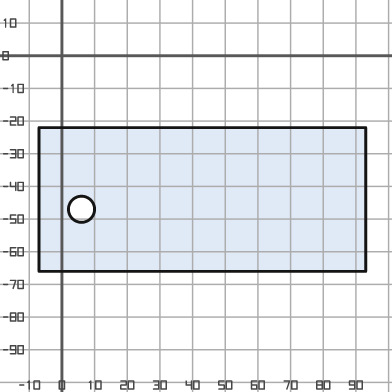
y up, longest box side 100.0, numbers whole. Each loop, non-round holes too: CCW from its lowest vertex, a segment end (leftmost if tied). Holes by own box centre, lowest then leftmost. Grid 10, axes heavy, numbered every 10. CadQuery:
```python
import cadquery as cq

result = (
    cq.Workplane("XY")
    .moveTo(-7.0, -66.0)
    .lineTo(93.0, -66.0)
    .lineTo(93.0, -22.0)
    .lineTo(-7.0, -22.0)
    .close()
    .moveTo(6.0, -47.0)
    .circle(4.0)
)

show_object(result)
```